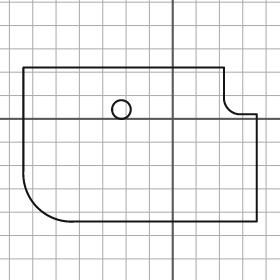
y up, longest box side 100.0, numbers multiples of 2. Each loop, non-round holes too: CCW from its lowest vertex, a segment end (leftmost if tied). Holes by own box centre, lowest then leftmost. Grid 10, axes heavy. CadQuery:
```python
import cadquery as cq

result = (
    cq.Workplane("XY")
    .moveTo(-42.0, -44.0)
    .lineTo(36.0, -44.0)
    .lineTo(36.0, 2.0)
    .lineTo(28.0, 2.0)
    .threePointArc((24.0, 4.0), (22.0, 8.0))
    .lineTo(22.0, 22.0)
    .lineTo(-64.0, 22.0)
    .lineTo(-64.0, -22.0)
    .threePointArc((-58.0, -38.0), (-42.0, -44.0))
    .close()
    .moveTo(-22.0, 4.0)
    .circle(4.0)
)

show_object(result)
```